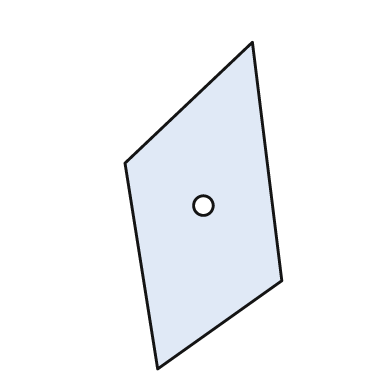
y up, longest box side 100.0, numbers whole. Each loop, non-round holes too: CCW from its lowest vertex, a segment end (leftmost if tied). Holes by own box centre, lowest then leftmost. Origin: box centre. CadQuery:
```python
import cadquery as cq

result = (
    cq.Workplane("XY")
    .moveTo(-14.0, -50.0)
    .lineTo(24.0, -23.0)
    .lineTo(15.0, 50.0)
    .lineTo(-24.0, 13.0)
    .close()
    .moveTo(0.0, 0.0)
    .circle(3.0)
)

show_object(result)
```